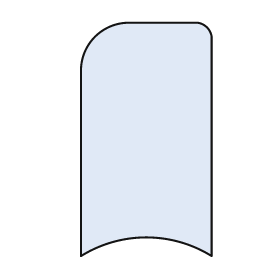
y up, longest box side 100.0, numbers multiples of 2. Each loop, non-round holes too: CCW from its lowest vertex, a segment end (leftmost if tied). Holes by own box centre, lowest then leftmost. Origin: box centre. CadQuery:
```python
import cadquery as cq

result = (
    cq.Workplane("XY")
    .moveTo(-28.0, -50.0)
    .threePointArc((0.0, -42.0), (28.0, -50.0))
    .lineTo(28.0, 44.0)
    .threePointArc((26.0, 48.0), (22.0, 50.0))
    .lineTo(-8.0, 50.0)
    .threePointArc((-22.0, 44.0), (-28.0, 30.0))
    .close()
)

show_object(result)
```